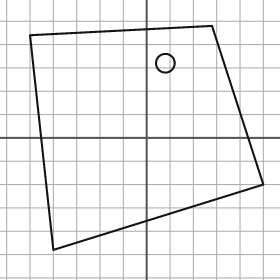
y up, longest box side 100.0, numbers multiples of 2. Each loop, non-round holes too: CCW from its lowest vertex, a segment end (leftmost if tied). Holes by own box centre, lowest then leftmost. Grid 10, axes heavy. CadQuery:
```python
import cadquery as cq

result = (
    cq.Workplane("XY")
    .moveTo(-40.0, -48.0)
    .lineTo(50.0, -20.0)
    .lineTo(28.0, 48.0)
    .lineTo(-50.0, 44.0)
    .close()
    .moveTo(8.0, 32.0)
    .circle(4.0)
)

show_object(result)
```